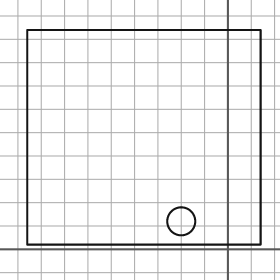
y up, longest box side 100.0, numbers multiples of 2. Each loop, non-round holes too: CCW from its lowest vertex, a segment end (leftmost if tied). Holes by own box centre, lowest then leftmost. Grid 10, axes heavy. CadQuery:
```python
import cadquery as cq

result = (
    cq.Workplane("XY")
    .moveTo(-86.0, 2.0)
    .lineTo(14.0, 2.0)
    .lineTo(14.0, 94.0)
    .lineTo(-86.0, 94.0)
    .close()
    .moveTo(-20.0, 12.0)
    .circle(6.0)
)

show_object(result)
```